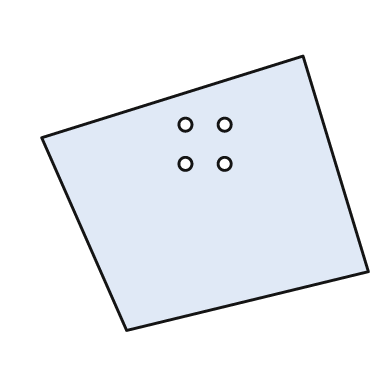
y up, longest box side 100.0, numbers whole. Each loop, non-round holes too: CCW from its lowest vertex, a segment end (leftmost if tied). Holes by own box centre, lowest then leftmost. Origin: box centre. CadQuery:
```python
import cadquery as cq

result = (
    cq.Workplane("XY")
    .moveTo(-24.0, -42.0)
    .lineTo(50.0, -24.0)
    .lineTo(30.0, 42.0)
    .lineTo(-50.0, 17.0)
    .close()
    .moveTo(-6.0, 9.0)
    .circle(2.0)
    .moveTo(6.0, 9.0)
    .circle(2.0)
    .moveTo(-6.0, 21.0)
    .circle(2.0)
    .moveTo(6.0, 21.0)
    .circle(2.0)
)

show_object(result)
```